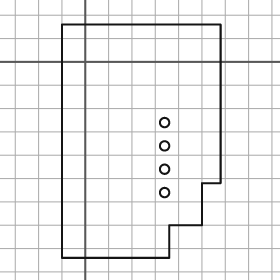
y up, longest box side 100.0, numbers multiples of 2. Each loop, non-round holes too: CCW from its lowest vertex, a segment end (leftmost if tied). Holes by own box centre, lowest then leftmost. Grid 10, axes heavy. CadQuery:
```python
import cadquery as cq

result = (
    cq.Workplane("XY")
    .moveTo(-10.0, -84.0)
    .lineTo(36.0, -84.0)
    .lineTo(36.0, -70.0)
    .lineTo(50.0, -70.0)
    .lineTo(50.0, -52.0)
    .lineTo(58.0, -52.0)
    .lineTo(58.0, 16.0)
    .lineTo(-10.0, 16.0)
    .close()
    .moveTo(34.0, -56.0)
    .circle(2.0)
    .moveTo(34.0, -46.0)
    .circle(2.0)
    .moveTo(34.0, -36.0)
    .circle(2.0)
    .moveTo(34.0, -26.0)
    .circle(2.0)
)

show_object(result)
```